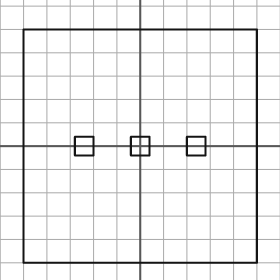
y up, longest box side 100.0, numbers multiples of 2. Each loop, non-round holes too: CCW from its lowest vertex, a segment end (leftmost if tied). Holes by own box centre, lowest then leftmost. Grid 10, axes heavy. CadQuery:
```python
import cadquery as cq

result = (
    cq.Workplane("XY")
    .moveTo(-50.0, -50.0)
    .lineTo(50.0, -50.0)
    .lineTo(50.0, 50.0)
    .lineTo(-50.0, 50.0)
    .close()
    .moveTo(-28.0, -4.0)
    .lineTo(-20.0, -4.0)
    .lineTo(-20.0, 4.0)
    .lineTo(-28.0, 4.0)
    .close()
    .moveTo(-4.0, -4.0)
    .lineTo(4.0, -4.0)
    .lineTo(4.0, 4.0)
    .lineTo(-4.0, 4.0)
    .close()
    .moveTo(20.0, -4.0)
    .lineTo(28.0, -4.0)
    .lineTo(28.0, 4.0)
    .lineTo(20.0, 4.0)
    .close()
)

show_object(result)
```